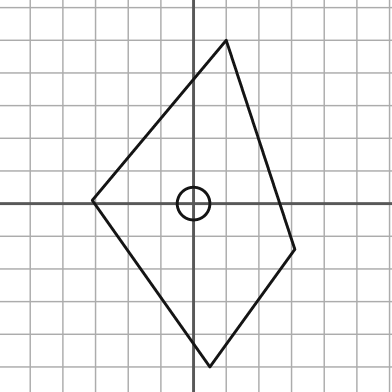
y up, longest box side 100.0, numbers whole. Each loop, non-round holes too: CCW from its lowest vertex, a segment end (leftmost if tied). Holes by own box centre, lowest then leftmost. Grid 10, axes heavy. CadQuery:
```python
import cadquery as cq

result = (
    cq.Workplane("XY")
    .moveTo(5.0, -50.0)
    .lineTo(31.0, -14.0)
    .lineTo(10.0, 50.0)
    .lineTo(-31.0, 1.0)
    .close()
    .moveTo(0.0, 0.0)
    .circle(5.0)
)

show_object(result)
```